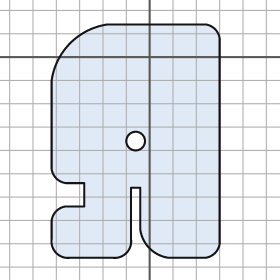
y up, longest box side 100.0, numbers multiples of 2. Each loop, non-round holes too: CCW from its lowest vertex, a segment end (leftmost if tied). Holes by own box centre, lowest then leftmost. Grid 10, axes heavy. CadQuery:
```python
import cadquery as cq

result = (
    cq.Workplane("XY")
    .moveTo(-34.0, -86.0)
    .lineTo(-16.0, -86.0)
    .threePointArc((-10.0, -84.0), (-8.0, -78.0))
    .lineTo(-8.0, -56.0)
    .lineTo(-4.0, -56.0)
    .lineTo(-4.0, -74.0)
    .threePointArc((0.0, -82.0), (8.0, -86.0))
    .lineTo(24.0, -86.0)
    .threePointArc((28.0, -84.0), (30.0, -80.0))
    .lineTo(30.0, 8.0)
    .threePointArc((28.0, 12.0), (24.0, 14.0))
    .lineTo(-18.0, 14.0)
    .threePointArc((-34.0, 6.0), (-42.0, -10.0))
    .lineTo(-42.0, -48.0)
    .threePointArc((-40.0, -52.0), (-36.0, -54.0))
    .lineTo(-28.0, -54.0)
    .lineTo(-28.0, -64.0)
    .lineTo(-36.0, -64.0)
    .threePointArc((-40.0, -66.0), (-42.0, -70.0))
    .lineTo(-42.0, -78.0)
    .threePointArc((-40.0, -84.0), (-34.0, -86.0))
    .close()
    .moveTo(-6.0, -36.0)
    .circle(4.0)
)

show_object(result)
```